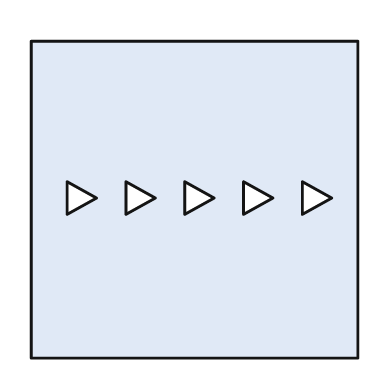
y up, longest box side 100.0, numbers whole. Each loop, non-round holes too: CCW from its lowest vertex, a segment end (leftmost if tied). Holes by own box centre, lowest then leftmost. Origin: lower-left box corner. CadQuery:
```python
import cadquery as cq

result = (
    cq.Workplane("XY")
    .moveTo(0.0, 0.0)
    .lineTo(100.0, 0.0)
    .lineTo(100.0, 97.0)
    .lineTo(0.0, 97.0)
    .close()
    .moveTo(11.0, 44.0)
    .lineTo(20.0, 49.0)
    .lineTo(11.0, 54.0)
    .close()
    .moveTo(29.0, 44.0)
    .lineTo(38.0, 49.0)
    .lineTo(29.0, 54.0)
    .close()
    .moveTo(47.0, 44.0)
    .lineTo(56.0, 49.0)
    .lineTo(47.0, 54.0)
    .close()
    .moveTo(65.0, 44.0)
    .lineTo(74.0, 49.0)
    .lineTo(65.0, 54.0)
    .close()
    .moveTo(83.0, 44.0)
    .lineTo(92.0, 49.0)
    .lineTo(83.0, 54.0)
    .close()
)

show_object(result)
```